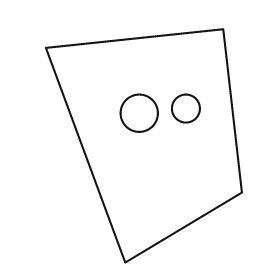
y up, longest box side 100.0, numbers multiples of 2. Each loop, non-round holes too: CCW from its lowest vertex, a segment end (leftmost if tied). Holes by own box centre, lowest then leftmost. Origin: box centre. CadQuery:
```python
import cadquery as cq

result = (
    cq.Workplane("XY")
    .moveTo(-8.0, -50.0)
    .lineTo(42.0, -20.0)
    .lineTo(34.0, 50.0)
    .lineTo(-42.0, 42.0)
    .close()
    .moveTo(-2.0, 14.0)
    .circle(8.0)
    .moveTo(18.0, 16.0)
    .circle(6.0)
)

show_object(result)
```